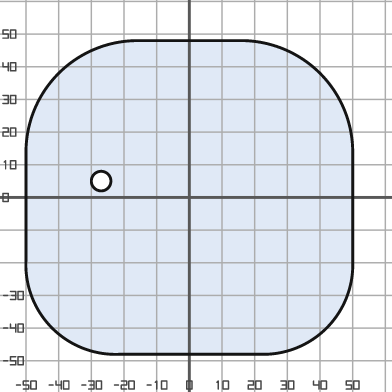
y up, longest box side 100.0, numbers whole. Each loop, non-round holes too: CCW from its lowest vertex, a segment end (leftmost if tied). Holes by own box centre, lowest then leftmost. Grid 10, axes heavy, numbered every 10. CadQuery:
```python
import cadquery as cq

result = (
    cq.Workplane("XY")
    .moveTo(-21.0, -48.0)
    .lineTo(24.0, -48.0)
    .threePointArc((42.0, -40.0), (50.0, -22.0))
    .lineTo(50.0, 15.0)
    .threePointArc((40.0, 38.0), (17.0, 48.0))
    .lineTo(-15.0, 48.0)
    .threePointArc((-40.0, 38.0), (-50.0, 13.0))
    .lineTo(-50.0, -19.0)
    .threePointArc((-42.0, -40.0), (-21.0, -48.0))
    .close()
    .moveTo(-27.0, 5.0)
    .circle(3.0)
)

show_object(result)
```